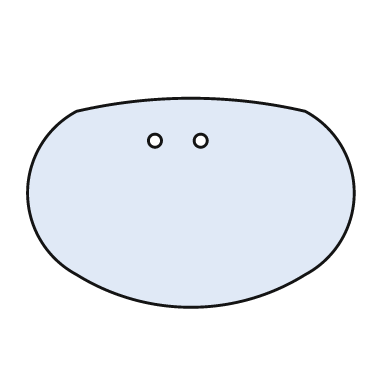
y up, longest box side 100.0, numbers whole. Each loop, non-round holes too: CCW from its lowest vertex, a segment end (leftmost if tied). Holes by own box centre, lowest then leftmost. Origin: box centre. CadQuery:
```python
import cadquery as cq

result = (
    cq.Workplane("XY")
    .moveTo(-35.0, -22.0)
    .threePointArc((0.0, -32.0), (35.0, -22.0))
    .threePointArc((50.0, 3.0), (35.0, 28.0))
    .threePointArc((0.0, 32.0), (-35.0, 28.0))
    .threePointArc((-50.0, 3.0), (-35.0, -22.0))
    .close()
    .moveTo(-11.0, 19.0)
    .circle(2.0)
    .moveTo(3.0, 19.0)
    .circle(2.0)
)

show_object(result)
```